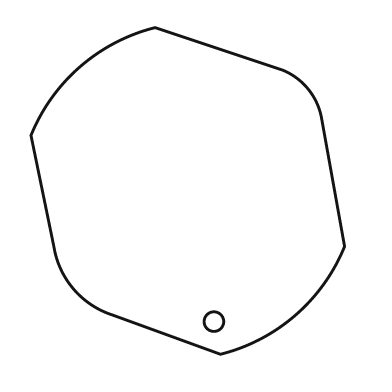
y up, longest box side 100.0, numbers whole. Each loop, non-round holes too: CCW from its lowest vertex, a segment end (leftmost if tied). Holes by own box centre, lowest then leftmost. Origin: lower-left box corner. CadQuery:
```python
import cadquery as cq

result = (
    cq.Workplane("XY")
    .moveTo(58.0, 0.0)
    .threePointArc((81.0, 12.0), (96.0, 33.0))
    .lineTo(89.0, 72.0)
    .threePointArc((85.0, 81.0), (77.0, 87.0))
    .lineTo(38.0, 100.0)
    .threePointArc((15.0, 88.0), (0.0, 67.0))
    .lineTo(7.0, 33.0)
    .threePointArc((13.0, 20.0), (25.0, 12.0))
    .close()
    .moveTo(56.0, 10.0)
    .circle(3.0)
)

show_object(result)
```